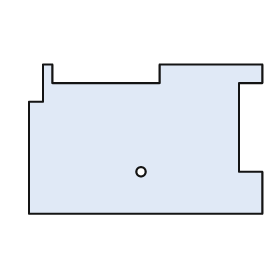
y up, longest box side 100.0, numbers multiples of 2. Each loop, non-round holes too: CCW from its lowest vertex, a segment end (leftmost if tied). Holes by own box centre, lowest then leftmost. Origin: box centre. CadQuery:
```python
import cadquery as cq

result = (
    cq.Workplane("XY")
    .moveTo(-50.0, -32.0)
    .lineTo(50.0, -32.0)
    .lineTo(50.0, -14.0)
    .lineTo(40.0, -14.0)
    .lineTo(40.0, 24.0)
    .lineTo(50.0, 24.0)
    .lineTo(50.0, 32.0)
    .lineTo(6.0, 32.0)
    .lineTo(6.0, 24.0)
    .lineTo(-40.0, 24.0)
    .lineTo(-40.0, 32.0)
    .lineTo(-44.0, 32.0)
    .lineTo(-44.0, 16.0)
    .lineTo(-50.0, 16.0)
    .close()
    .moveTo(-2.0, -14.0)
    .circle(2.0)
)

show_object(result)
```